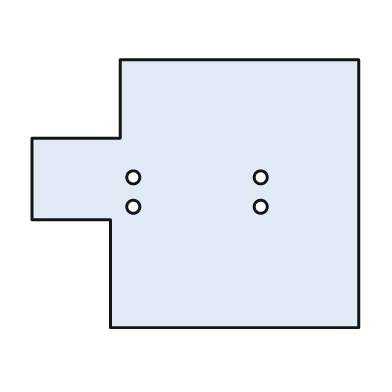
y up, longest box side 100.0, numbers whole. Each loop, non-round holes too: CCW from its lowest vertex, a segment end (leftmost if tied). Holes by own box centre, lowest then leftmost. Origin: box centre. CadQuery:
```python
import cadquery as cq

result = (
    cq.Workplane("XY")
    .moveTo(-26.0, -41.0)
    .lineTo(50.0, -41.0)
    .lineTo(50.0, 41.0)
    .lineTo(-23.0, 41.0)
    .lineTo(-23.0, 17.0)
    .lineTo(-50.0, 17.0)
    .lineTo(-50.0, -8.0)
    .lineTo(-26.0, -8.0)
    .close()
    .moveTo(-19.0, -4.0)
    .circle(2.0)
    .moveTo(20.0, -4.0)
    .circle(2.0)
    .moveTo(-19.0, 5.0)
    .circle(2.0)
    .moveTo(20.0, 5.0)
    .circle(2.0)
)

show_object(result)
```